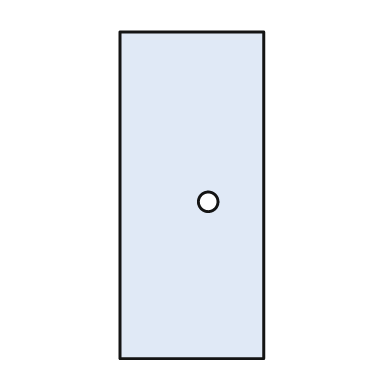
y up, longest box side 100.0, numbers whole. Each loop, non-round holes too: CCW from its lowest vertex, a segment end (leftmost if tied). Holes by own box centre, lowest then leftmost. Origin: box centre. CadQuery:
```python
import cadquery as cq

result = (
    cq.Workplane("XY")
    .moveTo(-22.0, -50.0)
    .lineTo(22.0, -50.0)
    .lineTo(22.0, 50.0)
    .lineTo(-22.0, 50.0)
    .close()
    .moveTo(5.0, -2.0)
    .circle(3.0)
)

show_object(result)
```